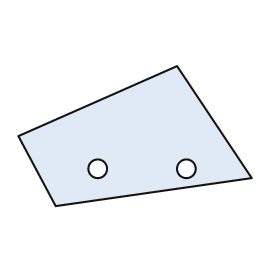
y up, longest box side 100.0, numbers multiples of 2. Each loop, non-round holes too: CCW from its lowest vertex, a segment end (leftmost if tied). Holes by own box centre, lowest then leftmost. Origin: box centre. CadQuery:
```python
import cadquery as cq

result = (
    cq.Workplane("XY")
    .moveTo(-34.0, -30.0)
    .lineTo(50.0, -18.0)
    .lineTo(18.0, 30.0)
    .lineTo(-50.0, 0.0)
    .close()
    .moveTo(-16.0, -14.0)
    .circle(4.0)
    .moveTo(22.0, -14.0)
    .circle(4.0)
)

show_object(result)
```